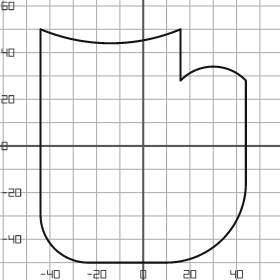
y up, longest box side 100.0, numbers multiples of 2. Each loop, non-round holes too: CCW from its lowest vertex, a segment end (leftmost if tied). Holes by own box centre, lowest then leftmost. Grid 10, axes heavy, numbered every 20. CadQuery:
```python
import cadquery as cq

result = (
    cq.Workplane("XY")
    .moveTo(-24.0, -50.0)
    .lineTo(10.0, -50.0)
    .threePointArc((34.0, -40.0), (44.0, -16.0))
    .lineTo(44.0, 28.0)
    .threePointArc((30.0, 34.0), (16.0, 28.0))
    .lineTo(16.0, 50.0)
    .threePointArc((-14.0, 44.0), (-44.0, 50.0))
    .lineTo(-44.0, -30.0)
    .threePointArc((-38.0, -44.0), (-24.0, -50.0))
    .close()
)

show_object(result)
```